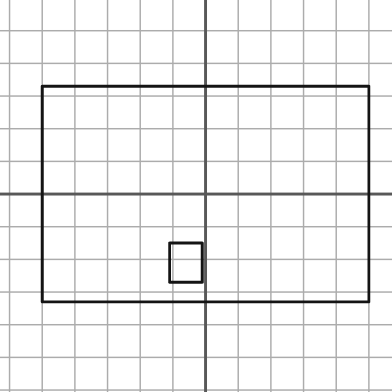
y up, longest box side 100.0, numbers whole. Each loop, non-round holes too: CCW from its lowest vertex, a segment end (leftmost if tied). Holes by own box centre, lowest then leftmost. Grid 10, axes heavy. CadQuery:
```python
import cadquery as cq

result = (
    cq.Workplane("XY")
    .moveTo(-50.0, -33.0)
    .lineTo(50.0, -33.0)
    .lineTo(50.0, 33.0)
    .lineTo(-50.0, 33.0)
    .close()
    .moveTo(-11.0, -27.0)
    .lineTo(-1.0, -27.0)
    .lineTo(-1.0, -15.0)
    .lineTo(-11.0, -15.0)
    .close()
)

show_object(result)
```